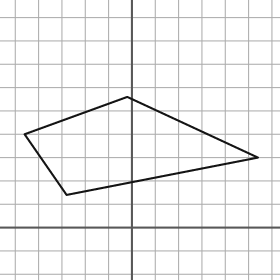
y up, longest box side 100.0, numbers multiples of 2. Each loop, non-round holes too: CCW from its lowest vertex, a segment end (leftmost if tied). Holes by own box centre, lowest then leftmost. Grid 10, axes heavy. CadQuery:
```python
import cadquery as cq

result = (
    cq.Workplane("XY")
    .moveTo(-28.0, 14.0)
    .lineTo(54.0, 30.0)
    .lineTo(-2.0, 56.0)
    .lineTo(-46.0, 40.0)
    .close()
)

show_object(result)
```